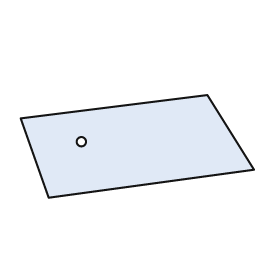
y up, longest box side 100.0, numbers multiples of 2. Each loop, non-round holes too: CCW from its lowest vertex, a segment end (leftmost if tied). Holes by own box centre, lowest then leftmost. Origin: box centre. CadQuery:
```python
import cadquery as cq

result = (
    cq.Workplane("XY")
    .moveTo(-38.0, -22.0)
    .lineTo(50.0, -10.0)
    .lineTo(30.0, 22.0)
    .lineTo(-50.0, 12.0)
    .close()
    .moveTo(-24.0, 2.0)
    .circle(2.0)
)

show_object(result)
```